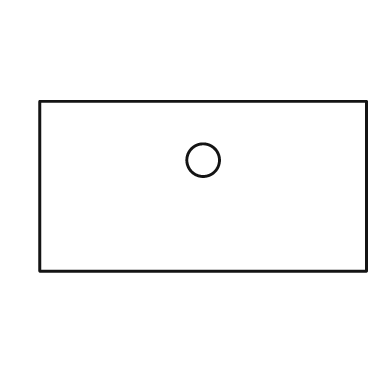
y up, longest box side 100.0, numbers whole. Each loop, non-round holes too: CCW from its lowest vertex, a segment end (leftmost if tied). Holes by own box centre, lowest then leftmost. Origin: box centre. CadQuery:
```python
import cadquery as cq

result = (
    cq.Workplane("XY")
    .moveTo(-50.0, -26.0)
    .lineTo(50.0, -26.0)
    .lineTo(50.0, 26.0)
    .lineTo(-50.0, 26.0)
    .close()
    .moveTo(0.0, 8.0)
    .circle(5.0)
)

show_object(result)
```